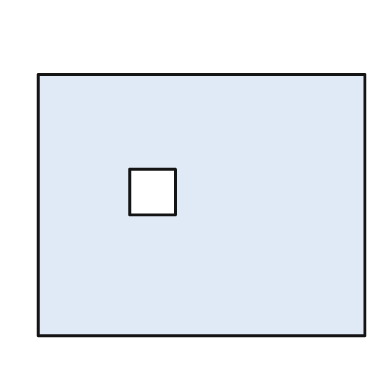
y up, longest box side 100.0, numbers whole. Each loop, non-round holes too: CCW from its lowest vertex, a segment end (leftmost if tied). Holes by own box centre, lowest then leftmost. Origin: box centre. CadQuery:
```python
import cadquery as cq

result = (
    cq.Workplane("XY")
    .moveTo(-50.0, -40.0)
    .lineTo(50.0, -40.0)
    .lineTo(50.0, 40.0)
    .lineTo(-50.0, 40.0)
    .close()
    .moveTo(-22.0, -3.0)
    .lineTo(-8.0, -3.0)
    .lineTo(-8.0, 11.0)
    .lineTo(-22.0, 11.0)
    .close()
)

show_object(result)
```